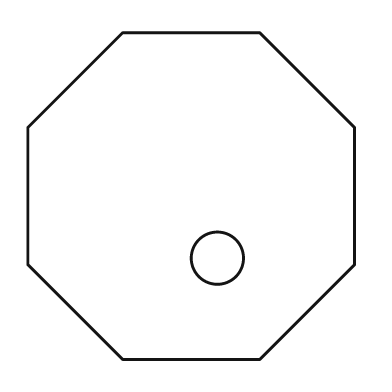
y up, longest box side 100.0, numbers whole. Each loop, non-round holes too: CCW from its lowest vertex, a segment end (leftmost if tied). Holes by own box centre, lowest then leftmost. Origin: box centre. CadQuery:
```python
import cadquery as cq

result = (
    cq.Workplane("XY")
    .moveTo(-21.0, -50.0)
    .lineTo(21.0, -50.0)
    .lineTo(50.0, -21.0)
    .lineTo(50.0, 21.0)
    .lineTo(21.0, 50.0)
    .lineTo(-21.0, 50.0)
    .lineTo(-50.0, 21.0)
    .lineTo(-50.0, -21.0)
    .close()
    .moveTo(8.0, -19.0)
    .circle(8.0)
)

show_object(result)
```